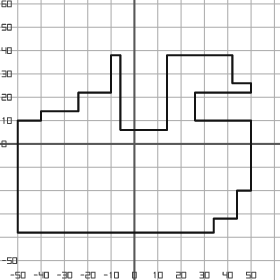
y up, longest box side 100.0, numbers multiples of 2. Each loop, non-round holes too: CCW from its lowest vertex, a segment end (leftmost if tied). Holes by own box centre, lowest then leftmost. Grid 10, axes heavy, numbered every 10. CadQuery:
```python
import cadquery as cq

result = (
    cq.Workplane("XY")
    .moveTo(-50.0, -38.0)
    .lineTo(34.0, -38.0)
    .lineTo(34.0, -32.0)
    .lineTo(44.0, -32.0)
    .lineTo(44.0, -20.0)
    .lineTo(50.0, -20.0)
    .lineTo(50.0, 10.0)
    .lineTo(26.0, 10.0)
    .lineTo(26.0, 22.0)
    .lineTo(50.0, 22.0)
    .lineTo(50.0, 26.0)
    .lineTo(42.0, 26.0)
    .lineTo(42.0, 38.0)
    .lineTo(14.0, 38.0)
    .lineTo(14.0, 6.0)
    .lineTo(-6.0, 6.0)
    .lineTo(-6.0, 38.0)
    .lineTo(-10.0, 38.0)
    .lineTo(-10.0, 22.0)
    .lineTo(-24.0, 22.0)
    .lineTo(-24.0, 14.0)
    .lineTo(-40.0, 14.0)
    .lineTo(-40.0, 10.0)
    .lineTo(-50.0, 10.0)
    .close()
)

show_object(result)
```